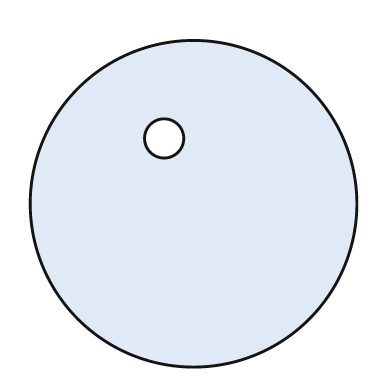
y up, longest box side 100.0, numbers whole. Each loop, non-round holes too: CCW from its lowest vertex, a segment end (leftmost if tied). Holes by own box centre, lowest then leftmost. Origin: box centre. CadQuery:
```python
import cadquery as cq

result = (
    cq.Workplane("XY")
    .moveTo(0.0, 0.0)
    .circle(50.0)
    .moveTo(-9.0, 20.0)
    .circle(6.0)
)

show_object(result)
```